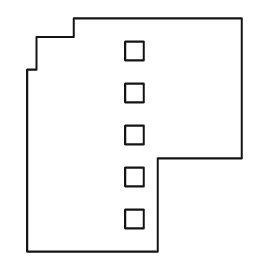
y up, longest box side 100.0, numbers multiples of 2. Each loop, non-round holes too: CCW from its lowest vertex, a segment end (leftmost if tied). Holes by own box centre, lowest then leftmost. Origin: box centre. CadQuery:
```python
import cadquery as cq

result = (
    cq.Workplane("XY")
    .moveTo(-46.0, -50.0)
    .lineTo(10.0, -50.0)
    .lineTo(10.0, -10.0)
    .lineTo(46.0, -10.0)
    .lineTo(46.0, 50.0)
    .lineTo(-26.0, 50.0)
    .lineTo(-26.0, 42.0)
    .lineTo(-42.0, 42.0)
    .lineTo(-42.0, 28.0)
    .lineTo(-46.0, 28.0)
    .close()
    .moveTo(-4.0, -40.0)
    .lineTo(4.0, -40.0)
    .lineTo(4.0, -32.0)
    .lineTo(-4.0, -32.0)
    .close()
    .moveTo(-4.0, -22.0)
    .lineTo(4.0, -22.0)
    .lineTo(4.0, -14.0)
    .lineTo(-4.0, -14.0)
    .close()
    .moveTo(-4.0, -4.0)
    .lineTo(4.0, -4.0)
    .lineTo(4.0, 4.0)
    .lineTo(-4.0, 4.0)
    .close()
    .moveTo(-4.0, 14.0)
    .lineTo(4.0, 14.0)
    .lineTo(4.0, 22.0)
    .lineTo(-4.0, 22.0)
    .close()
    .moveTo(-4.0, 32.0)
    .lineTo(4.0, 32.0)
    .lineTo(4.0, 40.0)
    .lineTo(-4.0, 40.0)
    .close()
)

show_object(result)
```